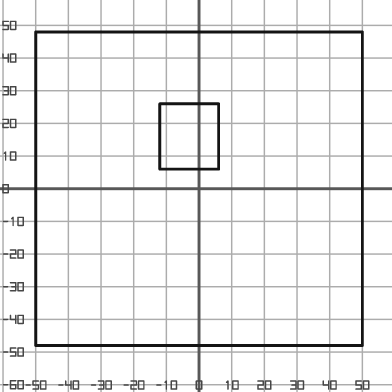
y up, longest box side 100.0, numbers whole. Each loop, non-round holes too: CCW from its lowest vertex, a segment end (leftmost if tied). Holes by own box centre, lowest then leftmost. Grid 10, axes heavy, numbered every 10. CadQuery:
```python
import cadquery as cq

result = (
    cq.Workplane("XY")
    .moveTo(-50.0, -48.0)
    .lineTo(50.0, -48.0)
    .lineTo(50.0, 48.0)
    .lineTo(-50.0, 48.0)
    .close()
    .moveTo(-12.0, 6.0)
    .lineTo(6.0, 6.0)
    .lineTo(6.0, 26.0)
    .lineTo(-12.0, 26.0)
    .close()
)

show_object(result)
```